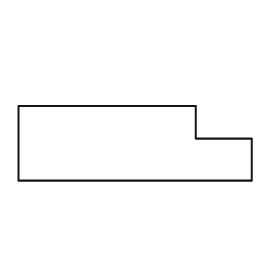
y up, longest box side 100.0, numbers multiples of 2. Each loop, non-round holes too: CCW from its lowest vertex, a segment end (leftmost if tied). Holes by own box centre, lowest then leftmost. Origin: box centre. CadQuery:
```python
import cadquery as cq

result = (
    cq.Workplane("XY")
    .moveTo(-50.0, -16.0)
    .lineTo(50.0, -16.0)
    .lineTo(50.0, 2.0)
    .lineTo(26.0, 2.0)
    .lineTo(26.0, 16.0)
    .lineTo(-50.0, 16.0)
    .close()
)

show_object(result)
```